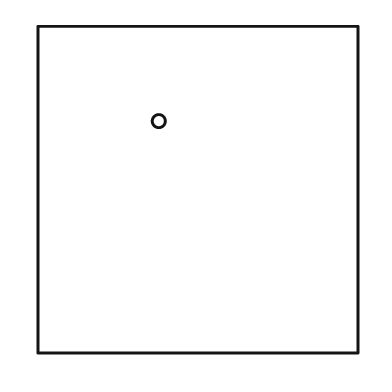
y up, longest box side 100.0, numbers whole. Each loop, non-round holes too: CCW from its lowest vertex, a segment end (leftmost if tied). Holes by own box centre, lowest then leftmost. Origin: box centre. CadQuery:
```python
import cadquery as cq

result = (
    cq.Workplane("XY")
    .moveTo(-49.0, -50.0)
    .lineTo(49.0, -50.0)
    .lineTo(49.0, 50.0)
    .lineTo(-49.0, 50.0)
    .close()
    .moveTo(-12.0, 21.0)
    .circle(2.0)
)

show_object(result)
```